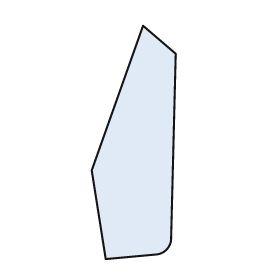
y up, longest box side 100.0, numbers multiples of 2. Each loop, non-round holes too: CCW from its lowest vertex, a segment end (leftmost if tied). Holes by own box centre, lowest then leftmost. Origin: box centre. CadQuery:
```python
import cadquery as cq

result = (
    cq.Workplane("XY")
    .moveTo(-12.0, -50.0)
    .lineTo(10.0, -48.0)
    .threePointArc((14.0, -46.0), (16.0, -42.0))
    .lineTo(18.0, 38.0)
    .lineTo(4.0, 50.0)
    .lineTo(-18.0, -12.0)
    .close()
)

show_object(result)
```